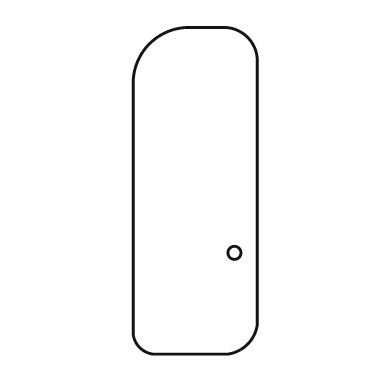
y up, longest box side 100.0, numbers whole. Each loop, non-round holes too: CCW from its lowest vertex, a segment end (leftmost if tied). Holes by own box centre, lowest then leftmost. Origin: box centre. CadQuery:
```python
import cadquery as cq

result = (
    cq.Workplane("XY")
    .moveTo(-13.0, -50.0)
    .lineTo(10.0, -50.0)
    .threePointArc((16.0, -47.0), (19.0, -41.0))
    .lineTo(19.0, 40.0)
    .threePointArc((16.0, 47.0), (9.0, 50.0))
    .lineTo(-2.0, 50.0)
    .threePointArc((-14.0, 45.0), (-19.0, 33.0))
    .lineTo(-19.0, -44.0)
    .threePointArc((-17.0, -48.0), (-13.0, -50.0))
    .close()
    .moveTo(12.0, -19.0)
    .circle(2.0)
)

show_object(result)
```